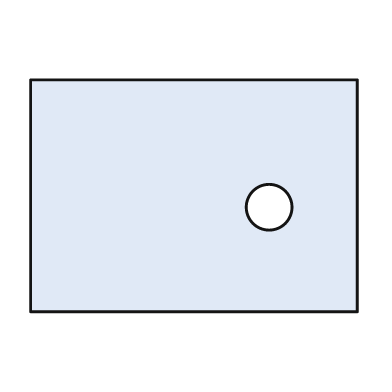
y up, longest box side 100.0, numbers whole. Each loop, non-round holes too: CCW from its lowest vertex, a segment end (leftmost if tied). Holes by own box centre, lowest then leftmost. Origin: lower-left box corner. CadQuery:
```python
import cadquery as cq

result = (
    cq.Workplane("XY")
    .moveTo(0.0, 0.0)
    .lineTo(100.0, 0.0)
    .lineTo(100.0, 71.0)
    .lineTo(0.0, 71.0)
    .close()
    .moveTo(73.0, 32.0)
    .circle(7.0)
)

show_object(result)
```